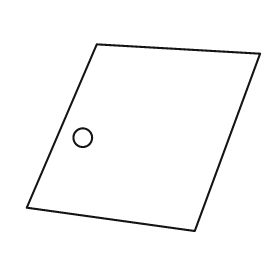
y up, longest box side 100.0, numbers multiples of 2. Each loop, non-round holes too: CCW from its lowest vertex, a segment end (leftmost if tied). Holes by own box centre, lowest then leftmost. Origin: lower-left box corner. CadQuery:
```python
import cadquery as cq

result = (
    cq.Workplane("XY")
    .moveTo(72.0, 0.0)
    .lineTo(100.0, 76.0)
    .lineTo(30.0, 80.0)
    .lineTo(0.0, 10.0)
    .close()
    .moveTo(24.0, 40.0)
    .circle(4.0)
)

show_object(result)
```